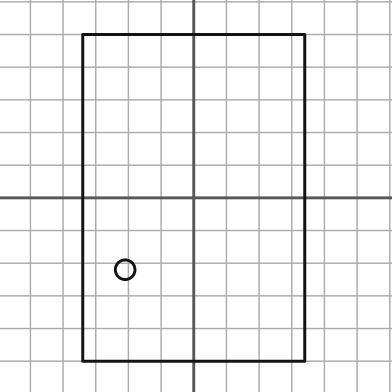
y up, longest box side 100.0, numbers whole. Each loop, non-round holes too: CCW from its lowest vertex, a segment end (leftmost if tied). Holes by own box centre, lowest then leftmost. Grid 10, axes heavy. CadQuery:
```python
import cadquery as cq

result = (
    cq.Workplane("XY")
    .moveTo(-34.0, -50.0)
    .lineTo(34.0, -50.0)
    .lineTo(34.0, 50.0)
    .lineTo(-34.0, 50.0)
    .close()
    .moveTo(-21.0, -22.0)
    .circle(3.0)
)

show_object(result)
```